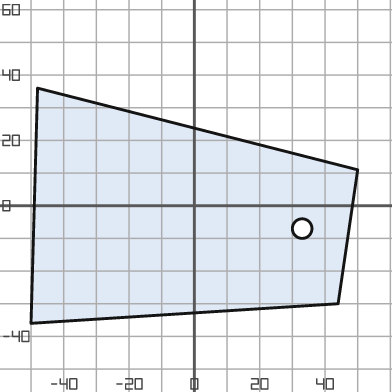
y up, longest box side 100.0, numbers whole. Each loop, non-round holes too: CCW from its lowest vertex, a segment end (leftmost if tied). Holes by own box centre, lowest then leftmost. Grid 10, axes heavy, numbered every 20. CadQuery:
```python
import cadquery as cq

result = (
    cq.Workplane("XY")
    .moveTo(-50.0, -36.0)
    .lineTo(44.0, -30.0)
    .lineTo(50.0, 11.0)
    .lineTo(-48.0, 36.0)
    .close()
    .moveTo(33.0, -7.0)
    .circle(3.0)
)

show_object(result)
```